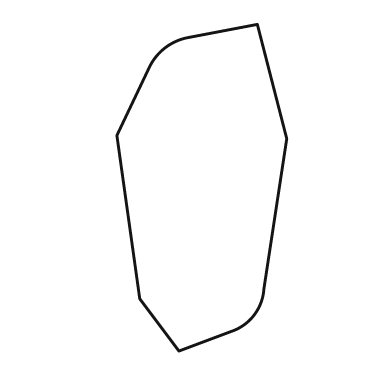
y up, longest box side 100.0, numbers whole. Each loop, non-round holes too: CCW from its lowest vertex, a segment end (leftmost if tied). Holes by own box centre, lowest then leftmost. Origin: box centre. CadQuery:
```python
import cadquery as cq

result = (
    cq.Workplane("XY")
    .moveTo(-7.0, -50.0)
    .lineTo(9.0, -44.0)
    .threePointArc((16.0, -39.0), (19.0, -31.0))
    .lineTo(26.0, 15.0)
    .lineTo(17.0, 50.0)
    .lineTo(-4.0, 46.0)
    .threePointArc((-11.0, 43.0), (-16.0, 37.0))
    .lineTo(-26.0, 16.0)
    .lineTo(-19.0, -34.0)
    .close()
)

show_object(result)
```